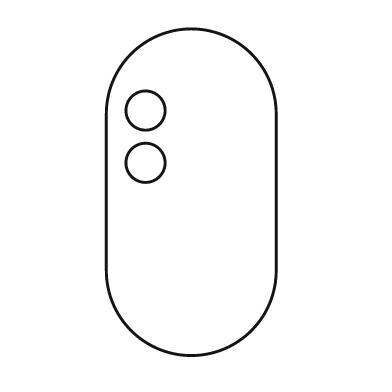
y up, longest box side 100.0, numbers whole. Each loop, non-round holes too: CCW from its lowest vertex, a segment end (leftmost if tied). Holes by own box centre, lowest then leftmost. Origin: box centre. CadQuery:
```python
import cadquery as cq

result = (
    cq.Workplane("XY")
    .moveTo(-26.0, -24.0)
    .threePointArc((0.0, -50.0), (26.0, -24.0))
    .lineTo(26.0, 24.0)
    .threePointArc((0.0, 50.0), (-26.0, 24.0))
    .close()
    .moveTo(-14.0, 9.0)
    .circle(6.0)
    .moveTo(-14.0, 25.0)
    .circle(6.0)
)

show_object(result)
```